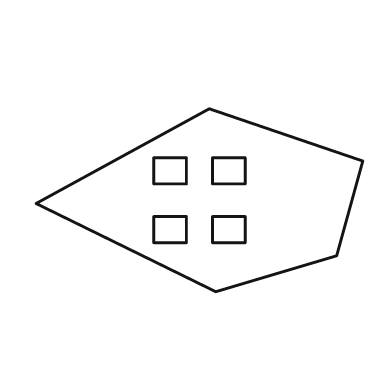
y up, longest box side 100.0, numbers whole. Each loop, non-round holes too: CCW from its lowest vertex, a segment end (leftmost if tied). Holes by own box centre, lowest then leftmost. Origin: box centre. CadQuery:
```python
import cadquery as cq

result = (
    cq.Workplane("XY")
    .moveTo(5.0, -28.0)
    .lineTo(42.0, -17.0)
    .lineTo(50.0, 12.0)
    .lineTo(3.0, 28.0)
    .lineTo(-50.0, -1.0)
    .close()
    .moveTo(-14.0, -13.0)
    .lineTo(-4.0, -13.0)
    .lineTo(-4.0, -5.0)
    .lineTo(-14.0, -5.0)
    .close()
    .moveTo(4.0, -13.0)
    .lineTo(14.0, -13.0)
    .lineTo(14.0, -5.0)
    .lineTo(4.0, -5.0)
    .close()
    .moveTo(-14.0, 5.0)
    .lineTo(-4.0, 5.0)
    .lineTo(-4.0, 13.0)
    .lineTo(-14.0, 13.0)
    .close()
    .moveTo(4.0, 5.0)
    .lineTo(14.0, 5.0)
    .lineTo(14.0, 13.0)
    .lineTo(4.0, 13.0)
    .close()
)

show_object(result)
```